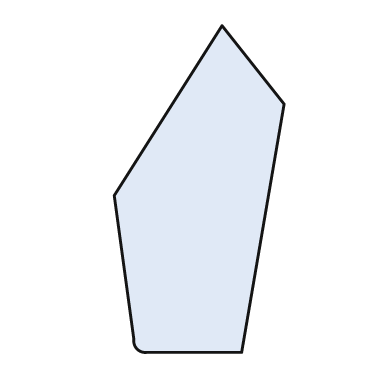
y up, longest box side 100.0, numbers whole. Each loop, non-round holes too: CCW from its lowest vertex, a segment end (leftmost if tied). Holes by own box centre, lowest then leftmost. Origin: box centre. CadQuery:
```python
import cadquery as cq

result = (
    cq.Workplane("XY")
    .moveTo(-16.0, -50.0)
    .lineTo(13.0, -50.0)
    .lineTo(26.0, 26.0)
    .lineTo(7.0, 50.0)
    .lineTo(-26.0, -2.0)
    .lineTo(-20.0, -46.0)
    .threePointArc((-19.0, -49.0), (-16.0, -50.0))
    .close()
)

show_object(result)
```